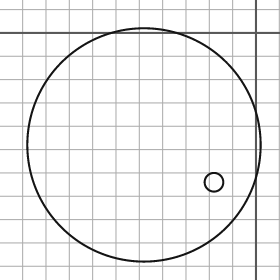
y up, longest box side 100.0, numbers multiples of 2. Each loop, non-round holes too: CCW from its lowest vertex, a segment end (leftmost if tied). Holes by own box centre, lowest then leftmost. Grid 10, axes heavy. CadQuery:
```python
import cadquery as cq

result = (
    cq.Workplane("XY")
    .moveTo(-48.0, -48.0)
    .circle(50.0)
    .moveTo(-18.0, -64.0)
    .circle(4.0)
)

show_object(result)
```